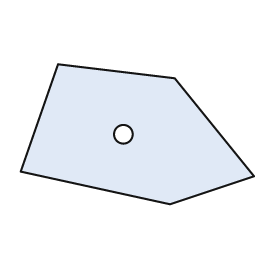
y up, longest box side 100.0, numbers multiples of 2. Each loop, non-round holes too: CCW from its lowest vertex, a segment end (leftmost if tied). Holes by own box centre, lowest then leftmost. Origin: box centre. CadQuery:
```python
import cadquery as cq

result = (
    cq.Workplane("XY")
    .moveTo(14.0, -30.0)
    .lineTo(50.0, -18.0)
    .lineTo(16.0, 24.0)
    .lineTo(-34.0, 30.0)
    .lineTo(-50.0, -16.0)
    .close()
    .moveTo(-6.0, 0.0)
    .circle(4.0)
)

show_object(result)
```